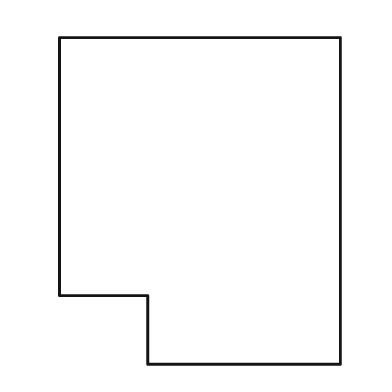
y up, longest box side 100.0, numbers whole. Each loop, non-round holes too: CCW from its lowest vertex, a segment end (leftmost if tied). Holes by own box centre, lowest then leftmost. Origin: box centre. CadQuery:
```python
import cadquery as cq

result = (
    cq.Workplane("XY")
    .moveTo(-16.0, -50.0)
    .lineTo(43.0, -50.0)
    .lineTo(43.0, 50.0)
    .lineTo(-43.0, 50.0)
    .lineTo(-43.0, -29.0)
    .lineTo(-16.0, -29.0)
    .close()
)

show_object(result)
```